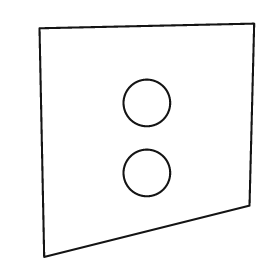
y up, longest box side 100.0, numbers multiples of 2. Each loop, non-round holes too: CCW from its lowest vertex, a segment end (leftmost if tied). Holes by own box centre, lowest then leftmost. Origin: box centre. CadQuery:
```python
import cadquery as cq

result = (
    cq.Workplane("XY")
    .moveTo(-44.0, -50.0)
    .lineTo(44.0, -28.0)
    .lineTo(46.0, 50.0)
    .lineTo(-46.0, 48.0)
    .close()
    .moveTo(0.0, -14.0)
    .circle(10.0)
    .moveTo(0.0, 16.0)
    .circle(10.0)
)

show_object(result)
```